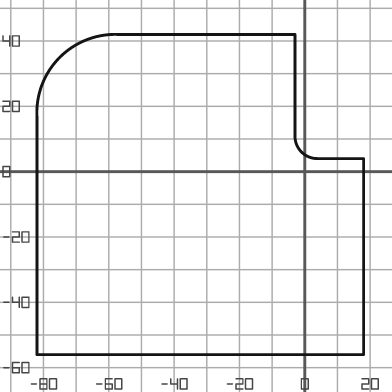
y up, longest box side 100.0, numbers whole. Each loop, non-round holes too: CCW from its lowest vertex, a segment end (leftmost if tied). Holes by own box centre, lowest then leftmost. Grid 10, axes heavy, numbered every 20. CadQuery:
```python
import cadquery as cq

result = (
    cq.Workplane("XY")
    .moveTo(-82.0, -56.0)
    .lineTo(18.0, -56.0)
    .lineTo(18.0, 4.0)
    .lineTo(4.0, 4.0)
    .threePointArc((-1.0, 6.0), (-3.0, 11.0))
    .lineTo(-3.0, 42.0)
    .lineTo(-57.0, 42.0)
    .threePointArc((-75.0, 35.0), (-82.0, 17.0))
    .close()
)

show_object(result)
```